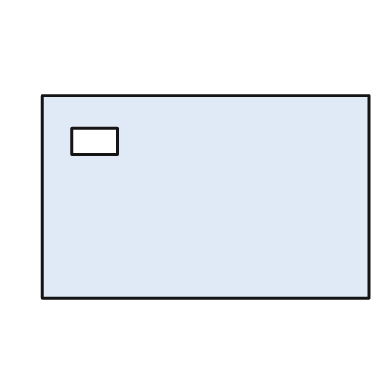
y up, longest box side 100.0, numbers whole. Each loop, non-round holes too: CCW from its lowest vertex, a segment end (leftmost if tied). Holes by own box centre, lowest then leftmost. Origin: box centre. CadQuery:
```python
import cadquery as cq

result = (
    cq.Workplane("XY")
    .moveTo(-50.0, -31.0)
    .lineTo(50.0, -31.0)
    .lineTo(50.0, 31.0)
    .lineTo(-50.0, 31.0)
    .close()
    .moveTo(-41.0, 13.0)
    .lineTo(-27.0, 13.0)
    .lineTo(-27.0, 21.0)
    .lineTo(-41.0, 21.0)
    .close()
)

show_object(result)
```